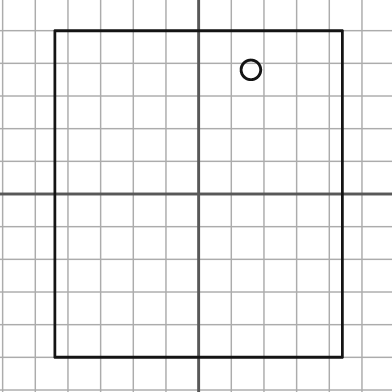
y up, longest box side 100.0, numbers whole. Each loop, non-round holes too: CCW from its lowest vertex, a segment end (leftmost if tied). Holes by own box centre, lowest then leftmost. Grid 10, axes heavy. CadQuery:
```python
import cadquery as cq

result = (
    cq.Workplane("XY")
    .moveTo(-44.0, -50.0)
    .lineTo(44.0, -50.0)
    .lineTo(44.0, 50.0)
    .lineTo(-44.0, 50.0)
    .close()
    .moveTo(16.0, 38.0)
    .circle(3.0)
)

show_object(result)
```